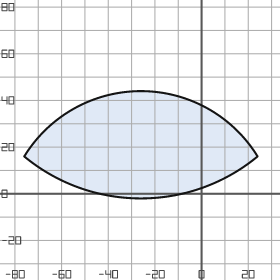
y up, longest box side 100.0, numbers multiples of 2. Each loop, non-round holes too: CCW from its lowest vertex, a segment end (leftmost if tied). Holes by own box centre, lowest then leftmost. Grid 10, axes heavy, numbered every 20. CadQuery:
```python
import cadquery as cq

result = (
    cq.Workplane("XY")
    .moveTo(-76.0, 16.0)
    .threePointArc((-26.0, -2.0), (24.0, 16.0))
    .threePointArc((-26.0, 44.0), (-76.0, 16.0))
    .close()
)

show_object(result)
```